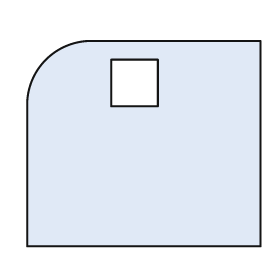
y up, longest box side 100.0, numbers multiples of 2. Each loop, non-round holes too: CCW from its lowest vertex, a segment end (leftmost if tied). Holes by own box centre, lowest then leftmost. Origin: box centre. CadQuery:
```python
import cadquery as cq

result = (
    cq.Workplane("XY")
    .moveTo(-50.0, -44.0)
    .lineTo(50.0, -44.0)
    .lineTo(50.0, 44.0)
    .lineTo(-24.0, 44.0)
    .threePointArc((-42.0, 36.0), (-50.0, 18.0))
    .close()
    .moveTo(-14.0, 16.0)
    .lineTo(6.0, 16.0)
    .lineTo(6.0, 36.0)
    .lineTo(-14.0, 36.0)
    .close()
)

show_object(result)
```